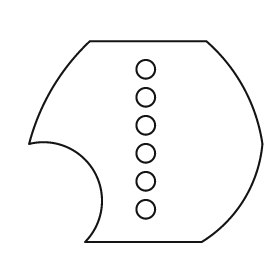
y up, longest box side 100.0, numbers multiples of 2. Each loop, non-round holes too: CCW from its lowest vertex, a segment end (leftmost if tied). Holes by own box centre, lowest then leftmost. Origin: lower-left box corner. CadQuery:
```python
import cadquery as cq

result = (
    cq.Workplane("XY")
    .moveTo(24.0, 0.0)
    .lineTo(74.0, 0.0)
    .threePointArc((92.0, 18.0), (100.0, 42.0))
    .threePointArc((92.0, 66.0), (76.0, 86.0))
    .lineTo(26.0, 86.0)
    .threePointArc((10.0, 66.0), (0.0, 42.0))
    .threePointArc((28.0, 30.0), (24.0, 0.0))
    .close()
    .moveTo(50.0, 14.0)
    .circle(4.0)
    .moveTo(50.0, 26.0)
    .circle(4.0)
    .moveTo(50.0, 38.0)
    .circle(4.0)
    .moveTo(50.0, 50.0)
    .circle(4.0)
    .moveTo(50.0, 62.0)
    .circle(4.0)
    .moveTo(50.0, 74.0)
    .circle(4.0)
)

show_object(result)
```